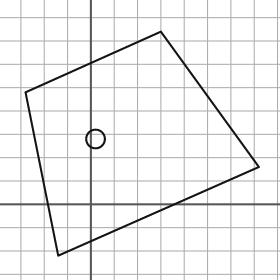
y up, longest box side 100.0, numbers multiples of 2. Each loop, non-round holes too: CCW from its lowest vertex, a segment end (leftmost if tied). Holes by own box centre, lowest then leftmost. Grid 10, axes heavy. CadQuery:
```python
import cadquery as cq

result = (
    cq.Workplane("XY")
    .moveTo(-14.0, -22.0)
    .lineTo(72.0, 16.0)
    .lineTo(30.0, 74.0)
    .lineTo(-28.0, 48.0)
    .close()
    .moveTo(2.0, 28.0)
    .circle(4.0)
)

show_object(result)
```